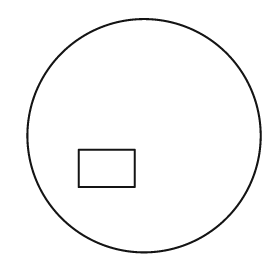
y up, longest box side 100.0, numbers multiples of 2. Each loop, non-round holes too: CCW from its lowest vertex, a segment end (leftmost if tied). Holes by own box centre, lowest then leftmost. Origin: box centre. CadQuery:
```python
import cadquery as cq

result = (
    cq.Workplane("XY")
    .moveTo(0.0, 0.0)
    .circle(50.0)
    .moveTo(-28.0, -22.0)
    .lineTo(-4.0, -22.0)
    .lineTo(-4.0, -6.0)
    .lineTo(-28.0, -6.0)
    .close()
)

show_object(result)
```